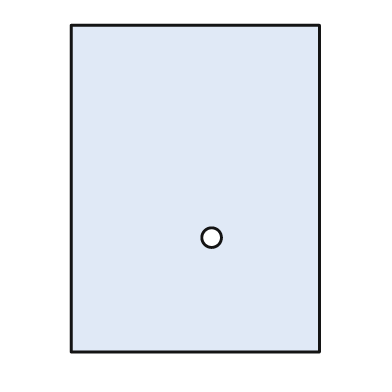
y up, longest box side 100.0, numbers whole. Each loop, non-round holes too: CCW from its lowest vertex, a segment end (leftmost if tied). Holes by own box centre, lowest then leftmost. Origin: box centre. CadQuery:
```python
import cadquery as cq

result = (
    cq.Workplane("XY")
    .moveTo(-38.0, -50.0)
    .lineTo(38.0, -50.0)
    .lineTo(38.0, 50.0)
    .lineTo(-38.0, 50.0)
    .close()
    .moveTo(5.0, -15.0)
    .circle(3.0)
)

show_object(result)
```